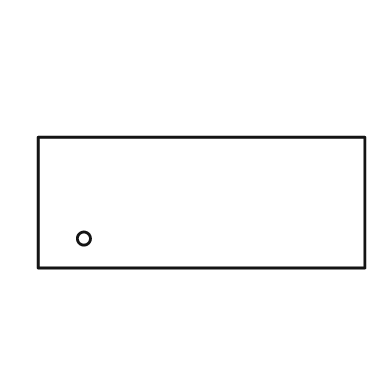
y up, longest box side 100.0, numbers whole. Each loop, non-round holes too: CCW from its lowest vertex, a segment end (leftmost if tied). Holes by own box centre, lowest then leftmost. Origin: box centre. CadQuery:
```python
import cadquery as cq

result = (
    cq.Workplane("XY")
    .moveTo(-50.0, -20.0)
    .lineTo(50.0, -20.0)
    .lineTo(50.0, 20.0)
    .lineTo(-50.0, 20.0)
    .close()
    .moveTo(-36.0, -11.0)
    .circle(2.0)
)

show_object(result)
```